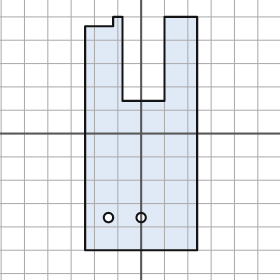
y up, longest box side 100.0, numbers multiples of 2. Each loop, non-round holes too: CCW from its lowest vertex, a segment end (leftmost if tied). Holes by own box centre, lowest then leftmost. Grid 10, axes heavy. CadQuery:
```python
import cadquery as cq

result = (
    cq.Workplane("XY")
    .moveTo(-24.0, -50.0)
    .lineTo(24.0, -50.0)
    .lineTo(24.0, 50.0)
    .lineTo(10.0, 50.0)
    .lineTo(10.0, 14.0)
    .lineTo(-8.0, 14.0)
    .lineTo(-8.0, 50.0)
    .lineTo(-12.0, 50.0)
    .lineTo(-12.0, 46.0)
    .lineTo(-24.0, 46.0)
    .close()
    .moveTo(-14.0, -36.0)
    .circle(2.0)
    .moveTo(0.0, -36.0)
    .circle(2.0)
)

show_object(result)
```